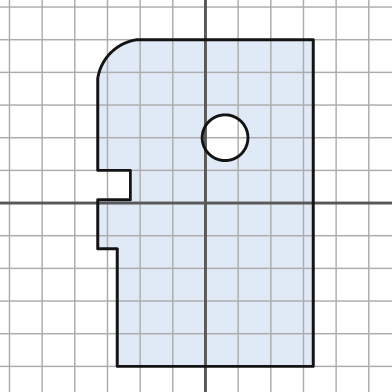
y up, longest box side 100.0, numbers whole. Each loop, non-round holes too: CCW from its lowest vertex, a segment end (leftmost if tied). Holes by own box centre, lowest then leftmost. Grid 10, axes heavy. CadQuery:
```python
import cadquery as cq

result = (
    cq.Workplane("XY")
    .moveTo(-27.0, -50.0)
    .lineTo(33.0, -50.0)
    .lineTo(33.0, 50.0)
    .lineTo(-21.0, 50.0)
    .threePointArc((-29.0, 46.0), (-33.0, 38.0))
    .lineTo(-33.0, 10.0)
    .lineTo(-23.0, 10.0)
    .lineTo(-23.0, 1.0)
    .lineTo(-33.0, 1.0)
    .lineTo(-33.0, -14.0)
    .lineTo(-27.0, -14.0)
    .close()
    .moveTo(6.0, 20.0)
    .circle(7.0)
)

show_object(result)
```